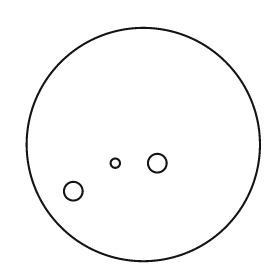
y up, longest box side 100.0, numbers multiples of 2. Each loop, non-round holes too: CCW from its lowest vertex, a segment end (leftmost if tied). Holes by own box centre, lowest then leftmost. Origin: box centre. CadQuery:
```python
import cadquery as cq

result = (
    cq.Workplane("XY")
    .moveTo(0.0, 0.0)
    .circle(50.0)
    .moveTo(-30.0, -20.0)
    .circle(4.0)
    .moveTo(-12.0, -8.0)
    .circle(2.0)
    .moveTo(6.0, -8.0)
    .circle(4.0)
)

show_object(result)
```